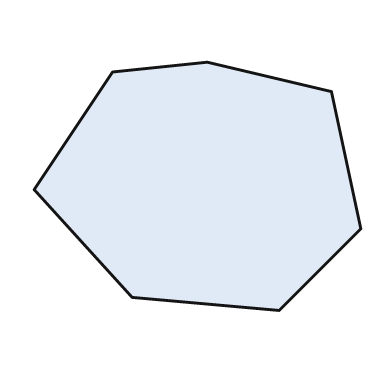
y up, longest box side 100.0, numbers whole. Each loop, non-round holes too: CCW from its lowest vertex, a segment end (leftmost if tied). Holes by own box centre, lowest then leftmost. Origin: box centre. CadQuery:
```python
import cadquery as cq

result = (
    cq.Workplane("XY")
    .moveTo(25.0, -38.0)
    .lineTo(50.0, -13.0)
    .lineTo(41.0, 29.0)
    .lineTo(3.0, 38.0)
    .lineTo(-26.0, 35.0)
    .lineTo(-50.0, -1.0)
    .lineTo(-20.0, -34.0)
    .close()
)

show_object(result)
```